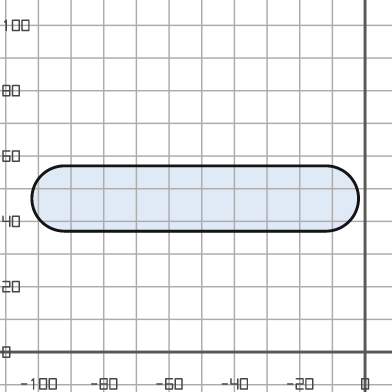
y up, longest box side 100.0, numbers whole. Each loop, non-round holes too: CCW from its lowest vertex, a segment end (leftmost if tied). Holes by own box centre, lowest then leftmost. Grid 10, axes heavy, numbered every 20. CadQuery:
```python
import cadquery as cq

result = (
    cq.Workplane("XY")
    .moveTo(-92.0, 37.0)
    .lineTo(-12.0, 37.0)
    .threePointArc((-2.0, 47.0), (-12.0, 57.0))
    .lineTo(-92.0, 57.0)
    .threePointArc((-102.0, 47.0), (-92.0, 37.0))
    .close()
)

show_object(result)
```